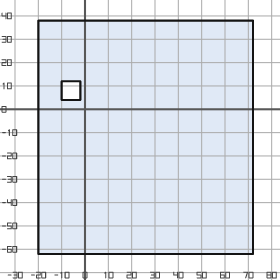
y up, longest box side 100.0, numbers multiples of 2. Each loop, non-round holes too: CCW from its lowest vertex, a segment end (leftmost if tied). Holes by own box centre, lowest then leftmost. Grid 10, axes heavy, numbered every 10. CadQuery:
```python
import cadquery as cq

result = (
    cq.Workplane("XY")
    .moveTo(-20.0, -62.0)
    .lineTo(72.0, -62.0)
    .lineTo(72.0, 38.0)
    .lineTo(-20.0, 38.0)
    .close()
    .moveTo(-10.0, 4.0)
    .lineTo(-2.0, 4.0)
    .lineTo(-2.0, 12.0)
    .lineTo(-10.0, 12.0)
    .close()
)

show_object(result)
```